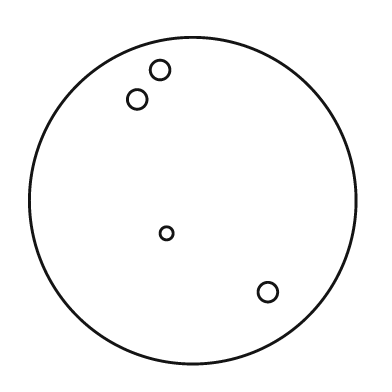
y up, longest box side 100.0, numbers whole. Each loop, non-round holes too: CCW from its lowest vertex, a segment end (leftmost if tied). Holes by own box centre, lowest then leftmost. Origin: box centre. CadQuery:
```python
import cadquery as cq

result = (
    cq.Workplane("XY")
    .moveTo(0.0, 0.0)
    .circle(50.0)
    .moveTo(23.0, -28.0)
    .circle(3.0)
    .moveTo(-8.0, -10.0)
    .circle(2.0)
    .moveTo(-17.0, 31.0)
    .circle(3.0)
    .moveTo(-10.0, 40.0)
    .circle(3.0)
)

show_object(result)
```